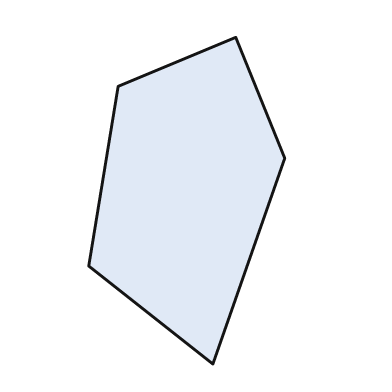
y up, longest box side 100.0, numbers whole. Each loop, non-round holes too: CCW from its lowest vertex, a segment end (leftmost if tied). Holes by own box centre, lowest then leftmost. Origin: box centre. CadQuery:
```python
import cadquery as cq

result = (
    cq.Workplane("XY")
    .moveTo(8.0, -50.0)
    .lineTo(30.0, 13.0)
    .lineTo(15.0, 50.0)
    .lineTo(-21.0, 35.0)
    .lineTo(-30.0, -20.0)
    .close()
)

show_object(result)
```